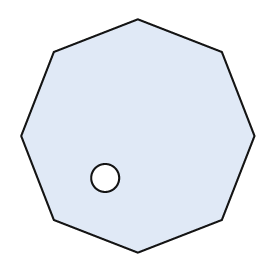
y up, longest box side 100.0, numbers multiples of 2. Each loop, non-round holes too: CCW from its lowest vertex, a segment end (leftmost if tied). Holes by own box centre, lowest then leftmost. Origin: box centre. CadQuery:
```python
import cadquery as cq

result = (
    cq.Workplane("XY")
    .moveTo(0.0, -50.0)
    .lineTo(36.0, -36.0)
    .lineTo(50.0, 0.0)
    .lineTo(36.0, 36.0)
    .lineTo(0.0, 50.0)
    .lineTo(-36.0, 36.0)
    .lineTo(-50.0, 0.0)
    .lineTo(-36.0, -36.0)
    .close()
    .moveTo(-14.0, -18.0)
    .circle(6.0)
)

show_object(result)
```